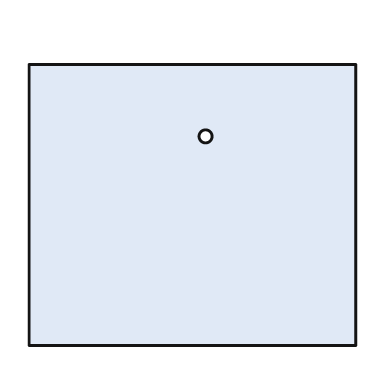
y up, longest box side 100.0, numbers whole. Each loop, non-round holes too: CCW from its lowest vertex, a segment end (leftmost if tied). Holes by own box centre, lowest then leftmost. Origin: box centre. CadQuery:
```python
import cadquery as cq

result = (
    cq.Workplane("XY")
    .moveTo(-50.0, -43.0)
    .lineTo(50.0, -43.0)
    .lineTo(50.0, 43.0)
    .lineTo(-50.0, 43.0)
    .close()
    .moveTo(4.0, 21.0)
    .circle(2.0)
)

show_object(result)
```